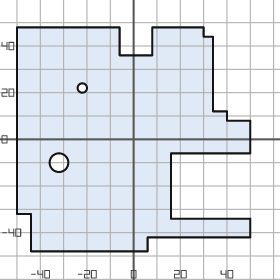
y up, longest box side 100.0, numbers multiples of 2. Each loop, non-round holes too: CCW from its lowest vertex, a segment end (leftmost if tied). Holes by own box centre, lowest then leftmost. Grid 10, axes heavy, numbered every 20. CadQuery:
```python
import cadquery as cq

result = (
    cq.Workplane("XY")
    .moveTo(-44.0, -48.0)
    .lineTo(6.0, -48.0)
    .lineTo(6.0, -42.0)
    .lineTo(50.0, -42.0)
    .lineTo(50.0, -34.0)
    .lineTo(16.0, -34.0)
    .lineTo(16.0, -6.0)
    .lineTo(50.0, -6.0)
    .lineTo(50.0, 8.0)
    .lineTo(40.0, 8.0)
    .lineTo(40.0, 12.0)
    .lineTo(34.0, 12.0)
    .lineTo(34.0, 44.0)
    .lineTo(30.0, 44.0)
    .lineTo(30.0, 48.0)
    .lineTo(8.0, 48.0)
    .lineTo(8.0, 36.0)
    .lineTo(-6.0, 36.0)
    .lineTo(-6.0, 48.0)
    .lineTo(-50.0, 48.0)
    .lineTo(-50.0, -32.0)
    .lineTo(-44.0, -32.0)
    .close()
    .moveTo(-32.0, -10.0)
    .circle(4.0)
    .moveTo(-22.0, 22.0)
    .circle(2.0)
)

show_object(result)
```